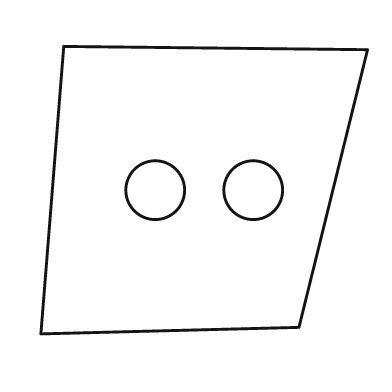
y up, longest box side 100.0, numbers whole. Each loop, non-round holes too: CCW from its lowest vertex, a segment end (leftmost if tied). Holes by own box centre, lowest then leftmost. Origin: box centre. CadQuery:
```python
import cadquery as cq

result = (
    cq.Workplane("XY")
    .moveTo(-50.0, -44.0)
    .lineTo(29.0, -42.0)
    .lineTo(50.0, 43.0)
    .lineTo(-43.0, 44.0)
    .close()
    .moveTo(-15.0, 0.0)
    .circle(9.0)
    .moveTo(15.0, 0.0)
    .circle(9.0)
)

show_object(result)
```